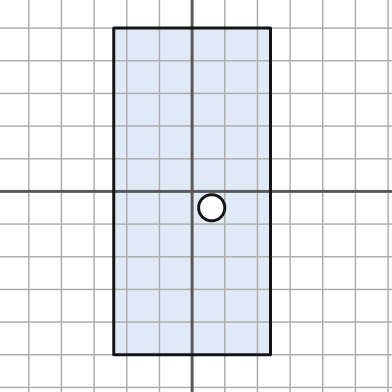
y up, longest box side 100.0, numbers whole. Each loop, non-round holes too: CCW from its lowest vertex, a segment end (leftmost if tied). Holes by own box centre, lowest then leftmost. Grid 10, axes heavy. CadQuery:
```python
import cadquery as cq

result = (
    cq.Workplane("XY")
    .moveTo(-24.0, -50.0)
    .lineTo(24.0, -50.0)
    .lineTo(24.0, 50.0)
    .lineTo(-24.0, 50.0)
    .close()
    .moveTo(6.0, -5.0)
    .circle(4.0)
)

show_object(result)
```